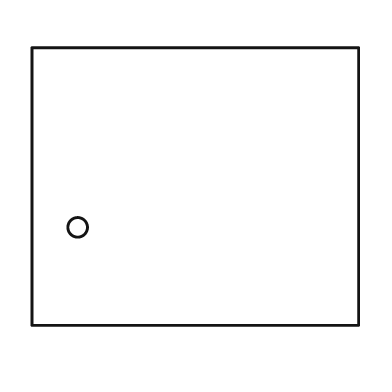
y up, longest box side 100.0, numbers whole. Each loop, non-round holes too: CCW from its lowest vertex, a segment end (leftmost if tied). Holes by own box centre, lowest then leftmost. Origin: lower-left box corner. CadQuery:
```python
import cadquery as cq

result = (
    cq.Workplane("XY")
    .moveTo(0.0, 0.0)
    .lineTo(100.0, 0.0)
    .lineTo(100.0, 85.0)
    .lineTo(0.0, 85.0)
    .close()
    .moveTo(14.0, 30.0)
    .circle(3.0)
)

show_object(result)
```